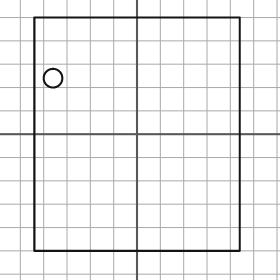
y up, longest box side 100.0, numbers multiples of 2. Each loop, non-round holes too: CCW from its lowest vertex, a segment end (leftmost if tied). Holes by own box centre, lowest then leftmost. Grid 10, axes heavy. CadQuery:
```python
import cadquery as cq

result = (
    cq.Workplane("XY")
    .moveTo(-44.0, -50.0)
    .lineTo(44.0, -50.0)
    .lineTo(44.0, 50.0)
    .lineTo(-44.0, 50.0)
    .close()
    .moveTo(-36.0, 24.0)
    .circle(4.0)
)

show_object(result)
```